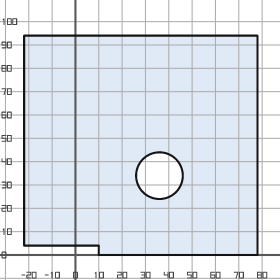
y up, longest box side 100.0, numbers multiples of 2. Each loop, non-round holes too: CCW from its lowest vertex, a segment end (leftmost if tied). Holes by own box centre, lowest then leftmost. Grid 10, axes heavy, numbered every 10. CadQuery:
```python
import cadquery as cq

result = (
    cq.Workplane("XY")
    .moveTo(10.0, 0.0)
    .lineTo(78.0, 0.0)
    .lineTo(78.0, 94.0)
    .lineTo(-22.0, 94.0)
    .lineTo(-22.0, 4.0)
    .lineTo(10.0, 4.0)
    .close()
    .moveTo(36.0, 34.0)
    .circle(10.0)
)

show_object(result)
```